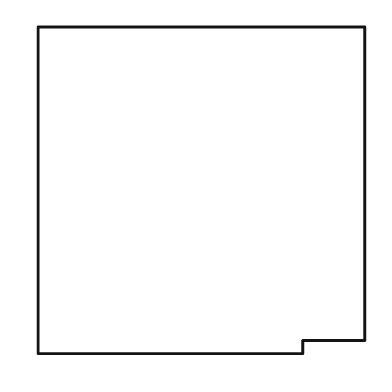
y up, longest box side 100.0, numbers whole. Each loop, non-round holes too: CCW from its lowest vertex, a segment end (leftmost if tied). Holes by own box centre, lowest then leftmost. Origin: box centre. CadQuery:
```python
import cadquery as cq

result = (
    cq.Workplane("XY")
    .moveTo(-50.0, -50.0)
    .lineTo(31.0, -50.0)
    .lineTo(31.0, -46.0)
    .lineTo(50.0, -46.0)
    .lineTo(50.0, 50.0)
    .lineTo(-50.0, 50.0)
    .close()
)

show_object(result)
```